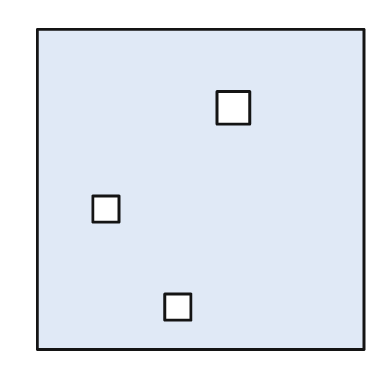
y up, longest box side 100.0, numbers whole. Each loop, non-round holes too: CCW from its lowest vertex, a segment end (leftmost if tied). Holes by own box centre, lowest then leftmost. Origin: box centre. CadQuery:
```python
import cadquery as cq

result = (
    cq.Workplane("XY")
    .moveTo(-50.0, -49.0)
    .lineTo(50.0, -49.0)
    .lineTo(50.0, 49.0)
    .lineTo(-50.0, 49.0)
    .close()
    .moveTo(-11.0, -40.0)
    .lineTo(-3.0, -40.0)
    .lineTo(-3.0, -32.0)
    .lineTo(-11.0, -32.0)
    .close()
    .moveTo(-33.0, -10.0)
    .lineTo(-25.0, -10.0)
    .lineTo(-25.0, -2.0)
    .lineTo(-33.0, -2.0)
    .close()
    .moveTo(5.0, 20.0)
    .lineTo(15.0, 20.0)
    .lineTo(15.0, 30.0)
    .lineTo(5.0, 30.0)
    .close()
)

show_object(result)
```